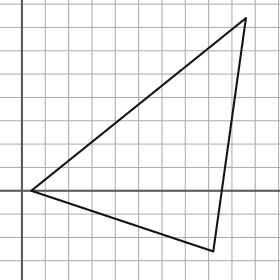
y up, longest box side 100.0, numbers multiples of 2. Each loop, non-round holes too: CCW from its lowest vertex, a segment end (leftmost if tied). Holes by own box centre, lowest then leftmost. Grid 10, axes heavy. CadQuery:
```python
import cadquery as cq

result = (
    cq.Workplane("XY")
    .moveTo(82.0, -26.0)
    .lineTo(96.0, 74.0)
    .lineTo(4.0, 0.0)
    .close()
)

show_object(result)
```